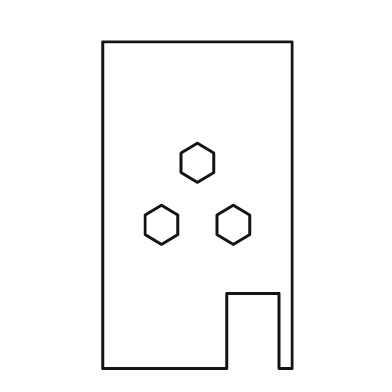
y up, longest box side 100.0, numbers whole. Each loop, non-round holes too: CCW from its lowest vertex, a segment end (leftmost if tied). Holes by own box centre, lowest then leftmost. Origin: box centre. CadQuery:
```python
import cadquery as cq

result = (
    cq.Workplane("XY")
    .moveTo(-29.0, -50.0)
    .lineTo(9.0, -50.0)
    .lineTo(9.0, -27.0)
    .lineTo(25.0, -27.0)
    .lineTo(25.0, -50.0)
    .lineTo(29.0, -50.0)
    .lineTo(29.0, 50.0)
    .lineTo(-29.0, 50.0)
    .close()
    .moveTo(-11.0, -12.0)
    .lineTo(-6.0, -9.0)
    .lineTo(-6.0, -3.0)
    .lineTo(-11.0, 0.0)
    .lineTo(-16.0, -3.0)
    .lineTo(-16.0, -9.0)
    .close()
    .moveTo(11.0, -12.0)
    .lineTo(16.0, -9.0)
    .lineTo(16.0, -3.0)
    .lineTo(11.0, 0.0)
    .lineTo(6.0, -3.0)
    .lineTo(6.0, -9.0)
    .close()
    .moveTo(0.0, 7.0)
    .lineTo(5.0, 10.0)
    .lineTo(5.0, 16.0)
    .lineTo(0.0, 19.0)
    .lineTo(-5.0, 16.0)
    .lineTo(-5.0, 10.0)
    .close()
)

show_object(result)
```